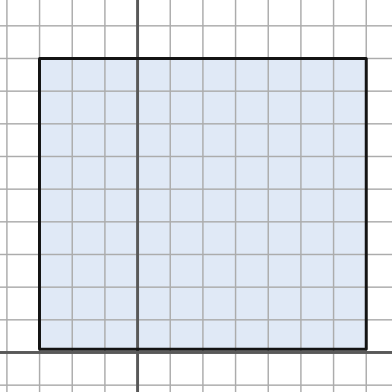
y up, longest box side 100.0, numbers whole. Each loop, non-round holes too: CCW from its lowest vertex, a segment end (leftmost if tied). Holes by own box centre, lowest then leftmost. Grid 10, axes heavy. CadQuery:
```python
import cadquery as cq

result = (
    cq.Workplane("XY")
    .moveTo(-30.0, 1.0)
    .lineTo(70.0, 1.0)
    .lineTo(70.0, 90.0)
    .lineTo(-30.0, 90.0)
    .close()
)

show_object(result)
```